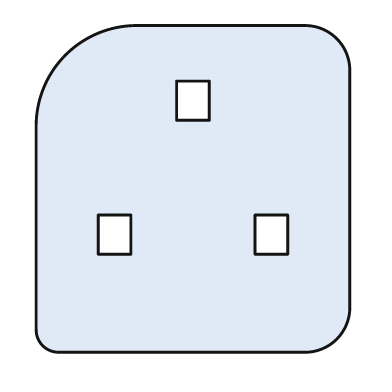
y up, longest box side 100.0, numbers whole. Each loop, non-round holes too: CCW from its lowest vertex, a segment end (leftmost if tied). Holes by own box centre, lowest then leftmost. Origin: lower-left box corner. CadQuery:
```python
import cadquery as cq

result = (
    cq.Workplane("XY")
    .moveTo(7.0, 0.0)
    .lineTo(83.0, 0.0)
    .threePointArc((92.0, 4.0), (96.0, 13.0))
    .lineTo(96.0, 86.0)
    .threePointArc((92.0, 96.0), (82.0, 100.0))
    .lineTo(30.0, 100.0)
    .threePointArc((9.0, 91.0), (0.0, 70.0))
    .lineTo(0.0, 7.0)
    .threePointArc((2.0, 2.0), (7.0, 0.0))
    .close()
    .moveTo(19.0, 30.0)
    .lineTo(29.0, 30.0)
    .lineTo(29.0, 42.0)
    .lineTo(19.0, 42.0)
    .close()
    .moveTo(67.0, 30.0)
    .lineTo(77.0, 30.0)
    .lineTo(77.0, 42.0)
    .lineTo(67.0, 42.0)
    .close()
    .moveTo(43.0, 71.0)
    .lineTo(53.0, 71.0)
    .lineTo(53.0, 83.0)
    .lineTo(43.0, 83.0)
    .close()
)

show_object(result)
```